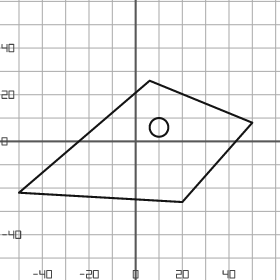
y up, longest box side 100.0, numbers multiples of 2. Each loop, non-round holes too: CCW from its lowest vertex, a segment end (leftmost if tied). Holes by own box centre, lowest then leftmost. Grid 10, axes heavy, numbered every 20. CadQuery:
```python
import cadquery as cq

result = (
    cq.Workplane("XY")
    .moveTo(20.0, -26.0)
    .lineTo(50.0, 8.0)
    .lineTo(6.0, 26.0)
    .lineTo(-50.0, -22.0)
    .close()
    .moveTo(10.0, 6.0)
    .circle(4.0)
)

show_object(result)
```